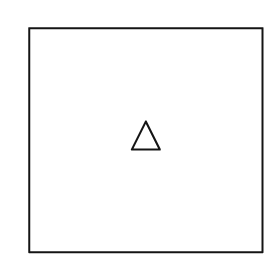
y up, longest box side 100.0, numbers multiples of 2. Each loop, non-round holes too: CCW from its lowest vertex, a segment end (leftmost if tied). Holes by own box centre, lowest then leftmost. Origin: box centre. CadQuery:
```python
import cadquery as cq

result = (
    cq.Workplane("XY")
    .moveTo(-50.0, -48.0)
    .lineTo(50.0, -48.0)
    .lineTo(50.0, 48.0)
    .lineTo(-50.0, 48.0)
    .close()
    .moveTo(-6.0, -4.0)
    .lineTo(6.0, -4.0)
    .lineTo(0.0, 8.0)
    .close()
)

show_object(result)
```